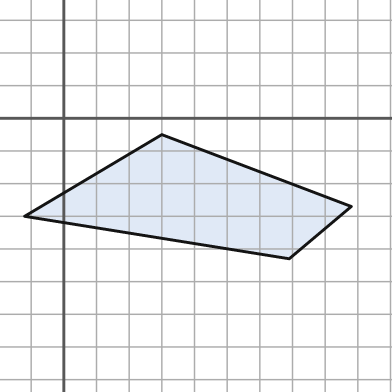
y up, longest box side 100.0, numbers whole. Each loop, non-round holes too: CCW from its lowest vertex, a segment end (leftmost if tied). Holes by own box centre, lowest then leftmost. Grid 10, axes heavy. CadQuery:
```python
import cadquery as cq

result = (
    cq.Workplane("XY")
    .moveTo(69.0, -43.0)
    .lineTo(88.0, -27.0)
    .lineTo(30.0, -5.0)
    .lineTo(-12.0, -30.0)
    .close()
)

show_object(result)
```